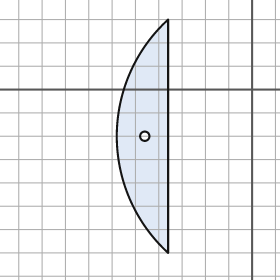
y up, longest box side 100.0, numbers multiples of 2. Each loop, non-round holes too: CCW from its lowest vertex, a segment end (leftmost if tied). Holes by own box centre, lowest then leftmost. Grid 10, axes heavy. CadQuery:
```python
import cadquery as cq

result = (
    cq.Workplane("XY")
    .moveTo(-36.0, -70.0)
    .lineTo(-36.0, 30.0)
    .threePointArc((-58.0, -20.0), (-36.0, -70.0))
    .close()
    .moveTo(-46.0, -20.0)
    .circle(2.0)
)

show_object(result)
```